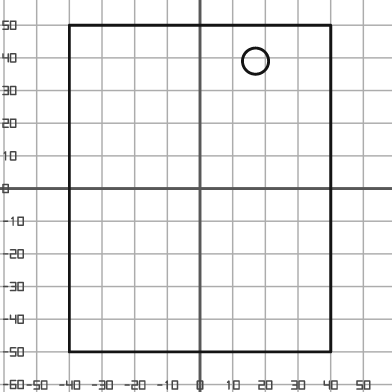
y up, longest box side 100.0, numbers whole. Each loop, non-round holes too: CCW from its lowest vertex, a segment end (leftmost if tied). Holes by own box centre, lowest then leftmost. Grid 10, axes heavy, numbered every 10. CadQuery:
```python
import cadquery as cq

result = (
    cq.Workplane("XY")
    .moveTo(-40.0, -50.0)
    .lineTo(40.0, -50.0)
    .lineTo(40.0, 50.0)
    .lineTo(-40.0, 50.0)
    .close()
    .moveTo(17.0, 39.0)
    .circle(4.0)
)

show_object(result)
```